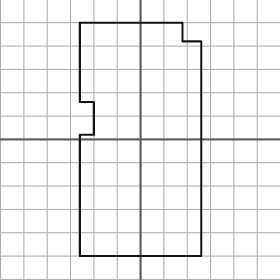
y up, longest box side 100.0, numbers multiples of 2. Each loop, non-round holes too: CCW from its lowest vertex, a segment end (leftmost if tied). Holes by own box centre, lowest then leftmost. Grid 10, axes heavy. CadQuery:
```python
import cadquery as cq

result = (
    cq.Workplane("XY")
    .moveTo(-26.0, -50.0)
    .lineTo(26.0, -50.0)
    .lineTo(26.0, 42.0)
    .lineTo(18.0, 42.0)
    .lineTo(18.0, 50.0)
    .lineTo(-26.0, 50.0)
    .lineTo(-26.0, 16.0)
    .lineTo(-20.0, 16.0)
    .lineTo(-20.0, 2.0)
    .lineTo(-26.0, 2.0)
    .close()
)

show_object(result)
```